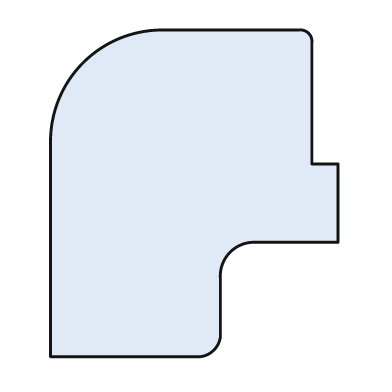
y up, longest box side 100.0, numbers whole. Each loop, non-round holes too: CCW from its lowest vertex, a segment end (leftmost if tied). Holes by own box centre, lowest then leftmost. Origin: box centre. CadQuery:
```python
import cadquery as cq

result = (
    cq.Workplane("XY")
    .moveTo(-44.0, -50.0)
    .lineTo(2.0, -50.0)
    .threePointArc((6.0, -48.0), (8.0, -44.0))
    .lineTo(8.0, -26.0)
    .threePointArc((11.0, -18.0), (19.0, -15.0))
    .lineTo(44.0, -15.0)
    .lineTo(44.0, 9.0)
    .lineTo(36.0, 9.0)
    .lineTo(36.0, 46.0)
    .threePointArc((35.0, 49.0), (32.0, 50.0))
    .lineTo(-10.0, 50.0)
    .threePointArc((-34.0, 40.0), (-44.0, 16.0))
    .close()
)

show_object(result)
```